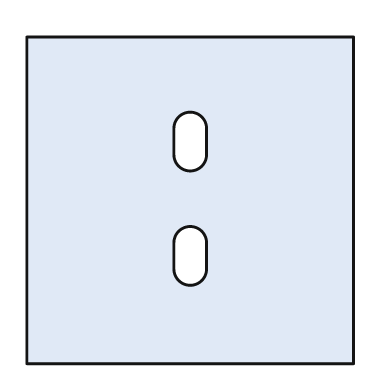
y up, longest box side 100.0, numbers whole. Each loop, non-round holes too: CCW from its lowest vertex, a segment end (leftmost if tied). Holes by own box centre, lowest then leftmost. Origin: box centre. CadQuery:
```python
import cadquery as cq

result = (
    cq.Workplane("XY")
    .moveTo(-50.0, -50.0)
    .lineTo(50.0, -50.0)
    .lineTo(50.0, 50.0)
    .lineTo(-50.0, 50.0)
    .close()
    .moveTo(-5.0, -21.0)
    .threePointArc((0.0, -26.0), (5.0, -21.0))
    .lineTo(5.0, -13.0)
    .threePointArc((0.0, -8.0), (-5.0, -13.0))
    .close()
    .moveTo(-5.0, 14.0)
    .threePointArc((0.0, 9.0), (5.0, 14.0))
    .lineTo(5.0, 22.0)
    .threePointArc((0.0, 27.0), (-5.0, 22.0))
    .close()
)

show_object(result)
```